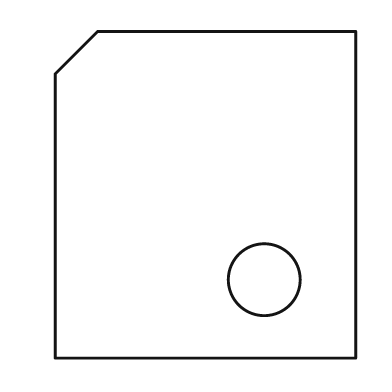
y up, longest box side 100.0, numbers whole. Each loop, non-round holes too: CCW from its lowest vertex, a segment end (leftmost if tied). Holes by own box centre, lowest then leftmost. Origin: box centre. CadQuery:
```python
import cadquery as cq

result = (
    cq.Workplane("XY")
    .moveTo(-46.0, -50.0)
    .lineTo(46.0, -50.0)
    .lineTo(46.0, 50.0)
    .lineTo(-33.0, 50.0)
    .lineTo(-46.0, 37.0)
    .close()
    .moveTo(18.0, -26.0)
    .circle(11.0)
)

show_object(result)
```